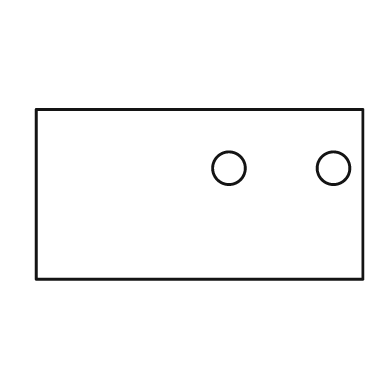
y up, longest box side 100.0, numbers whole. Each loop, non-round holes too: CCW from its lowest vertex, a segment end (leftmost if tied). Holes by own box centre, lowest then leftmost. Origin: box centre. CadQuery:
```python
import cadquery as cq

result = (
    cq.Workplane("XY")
    .moveTo(-50.0, -26.0)
    .lineTo(50.0, -26.0)
    .lineTo(50.0, 26.0)
    .lineTo(-50.0, 26.0)
    .close()
    .moveTo(9.0, 8.0)
    .circle(5.0)
    .moveTo(41.0, 8.0)
    .circle(5.0)
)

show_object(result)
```